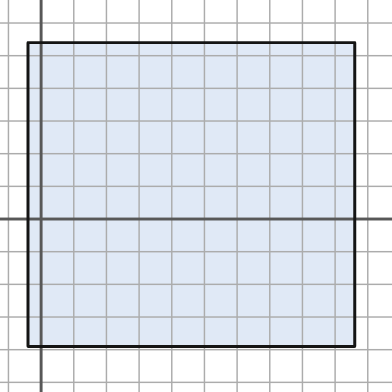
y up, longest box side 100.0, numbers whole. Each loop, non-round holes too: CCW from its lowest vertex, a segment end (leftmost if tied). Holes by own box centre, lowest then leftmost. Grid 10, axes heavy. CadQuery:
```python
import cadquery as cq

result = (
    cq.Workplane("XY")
    .moveTo(-4.0, -39.0)
    .lineTo(96.0, -39.0)
    .lineTo(96.0, 54.0)
    .lineTo(-4.0, 54.0)
    .close()
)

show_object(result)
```